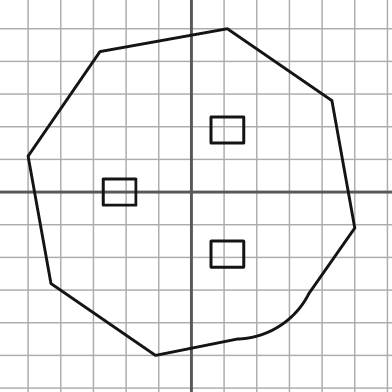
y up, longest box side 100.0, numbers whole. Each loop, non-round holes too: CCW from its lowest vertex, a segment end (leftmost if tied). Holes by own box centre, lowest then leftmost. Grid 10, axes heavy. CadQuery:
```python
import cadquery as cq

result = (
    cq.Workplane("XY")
    .moveTo(-11.0, -50.0)
    .lineTo(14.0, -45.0)
    .threePointArc((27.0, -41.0), (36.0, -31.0))
    .lineTo(50.0, -11.0)
    .lineTo(43.0, 28.0)
    .lineTo(11.0, 50.0)
    .lineTo(-28.0, 43.0)
    .lineTo(-50.0, 11.0)
    .lineTo(-43.0, -28.0)
    .close()
    .moveTo(6.0, -23.0)
    .lineTo(16.0, -23.0)
    .lineTo(16.0, -15.0)
    .lineTo(6.0, -15.0)
    .close()
    .moveTo(-27.0, -4.0)
    .lineTo(-17.0, -4.0)
    .lineTo(-17.0, 4.0)
    .lineTo(-27.0, 4.0)
    .close()
    .moveTo(6.0, 15.0)
    .lineTo(16.0, 15.0)
    .lineTo(16.0, 23.0)
    .lineTo(6.0, 23.0)
    .close()
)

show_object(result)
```